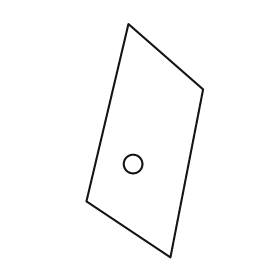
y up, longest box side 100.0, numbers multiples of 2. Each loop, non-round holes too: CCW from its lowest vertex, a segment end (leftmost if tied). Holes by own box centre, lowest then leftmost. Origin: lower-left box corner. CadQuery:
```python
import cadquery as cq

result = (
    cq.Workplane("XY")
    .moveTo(36.0, 0.0)
    .lineTo(50.0, 72.0)
    .lineTo(18.0, 100.0)
    .lineTo(0.0, 24.0)
    .close()
    .moveTo(20.0, 40.0)
    .circle(4.0)
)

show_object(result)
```